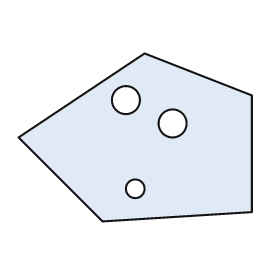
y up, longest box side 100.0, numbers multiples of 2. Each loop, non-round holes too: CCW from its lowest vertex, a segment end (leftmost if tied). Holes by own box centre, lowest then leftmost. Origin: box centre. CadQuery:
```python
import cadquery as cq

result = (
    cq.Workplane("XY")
    .moveTo(-14.0, -36.0)
    .lineTo(50.0, -32.0)
    .lineTo(50.0, 18.0)
    .lineTo(4.0, 36.0)
    .lineTo(-50.0, 0.0)
    .close()
    .moveTo(0.0, -22.0)
    .circle(4.0)
    .moveTo(16.0, 6.0)
    .circle(6.0)
    .moveTo(-4.0, 16.0)
    .circle(6.0)
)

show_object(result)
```